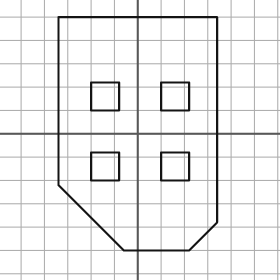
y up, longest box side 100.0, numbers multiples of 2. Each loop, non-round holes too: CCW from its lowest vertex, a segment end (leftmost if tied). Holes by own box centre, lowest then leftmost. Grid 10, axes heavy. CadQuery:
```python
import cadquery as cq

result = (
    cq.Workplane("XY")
    .moveTo(-6.0, -50.0)
    .lineTo(22.0, -50.0)
    .lineTo(34.0, -38.0)
    .lineTo(34.0, 50.0)
    .lineTo(-34.0, 50.0)
    .lineTo(-34.0, -22.0)
    .close()
    .moveTo(-20.0, -20.0)
    .lineTo(-8.0, -20.0)
    .lineTo(-8.0, -8.0)
    .lineTo(-20.0, -8.0)
    .close()
    .moveTo(10.0, -20.0)
    .lineTo(22.0, -20.0)
    .lineTo(22.0, -8.0)
    .lineTo(10.0, -8.0)
    .close()
    .moveTo(-20.0, 10.0)
    .lineTo(-8.0, 10.0)
    .lineTo(-8.0, 22.0)
    .lineTo(-20.0, 22.0)
    .close()
    .moveTo(10.0, 10.0)
    .lineTo(22.0, 10.0)
    .lineTo(22.0, 22.0)
    .lineTo(10.0, 22.0)
    .close()
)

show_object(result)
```